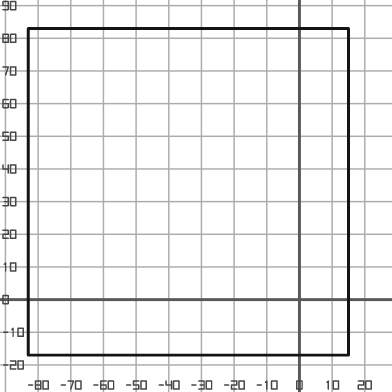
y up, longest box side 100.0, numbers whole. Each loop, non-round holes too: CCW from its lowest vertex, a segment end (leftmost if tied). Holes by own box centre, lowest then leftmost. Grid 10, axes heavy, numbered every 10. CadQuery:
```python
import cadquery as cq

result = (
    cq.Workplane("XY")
    .moveTo(-83.0, -17.0)
    .lineTo(15.0, -17.0)
    .lineTo(15.0, 83.0)
    .lineTo(-83.0, 83.0)
    .close()
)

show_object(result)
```